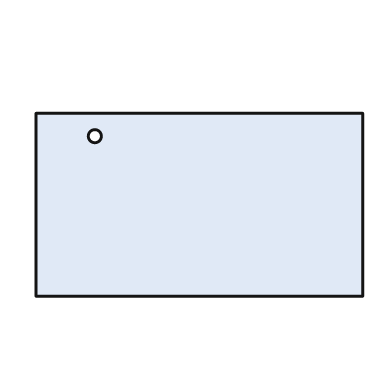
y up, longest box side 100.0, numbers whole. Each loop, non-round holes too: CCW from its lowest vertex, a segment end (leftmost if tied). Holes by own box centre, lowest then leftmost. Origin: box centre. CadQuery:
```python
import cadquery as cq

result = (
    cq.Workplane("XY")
    .moveTo(-50.0, -28.0)
    .lineTo(50.0, -28.0)
    .lineTo(50.0, 28.0)
    .lineTo(-50.0, 28.0)
    .close()
    .moveTo(-32.0, 21.0)
    .circle(2.0)
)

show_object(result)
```